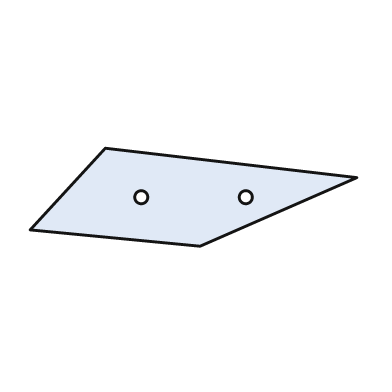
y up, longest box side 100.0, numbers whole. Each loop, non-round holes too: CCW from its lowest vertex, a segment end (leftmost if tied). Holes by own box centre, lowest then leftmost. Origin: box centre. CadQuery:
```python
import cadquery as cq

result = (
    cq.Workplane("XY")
    .moveTo(2.0, -15.0)
    .lineTo(50.0, 6.0)
    .lineTo(-27.0, 15.0)
    .lineTo(-50.0, -10.0)
    .close()
    .moveTo(-16.0, 0.0)
    .circle(2.0)
    .moveTo(16.0, 0.0)
    .circle(2.0)
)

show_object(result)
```